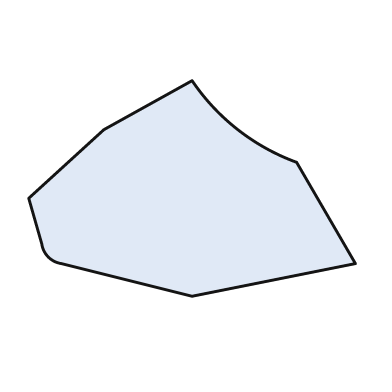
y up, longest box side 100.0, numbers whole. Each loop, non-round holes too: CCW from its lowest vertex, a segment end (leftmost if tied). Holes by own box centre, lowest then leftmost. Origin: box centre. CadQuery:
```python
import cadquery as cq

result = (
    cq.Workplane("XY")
    .moveTo(0.0, -33.0)
    .lineTo(50.0, -23.0)
    .lineTo(32.0, 8.0)
    .threePointArc((14.0, 18.0), (0.0, 33.0))
    .lineTo(-27.0, 18.0)
    .lineTo(-50.0, -3.0)
    .lineTo(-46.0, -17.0)
    .threePointArc((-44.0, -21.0), (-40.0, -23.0))
    .close()
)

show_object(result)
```